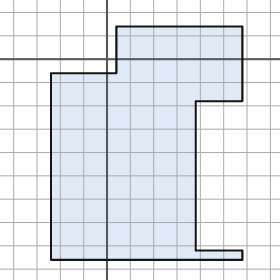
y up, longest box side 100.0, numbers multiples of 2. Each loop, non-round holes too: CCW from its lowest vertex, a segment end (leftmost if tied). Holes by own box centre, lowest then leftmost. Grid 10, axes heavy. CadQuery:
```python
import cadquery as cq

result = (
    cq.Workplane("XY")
    .moveTo(-24.0, -86.0)
    .lineTo(58.0, -86.0)
    .lineTo(58.0, -82.0)
    .lineTo(38.0, -82.0)
    .lineTo(38.0, -18.0)
    .lineTo(58.0, -18.0)
    .lineTo(58.0, 14.0)
    .lineTo(4.0, 14.0)
    .lineTo(4.0, -6.0)
    .lineTo(-24.0, -6.0)
    .close()
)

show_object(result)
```